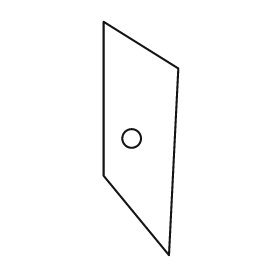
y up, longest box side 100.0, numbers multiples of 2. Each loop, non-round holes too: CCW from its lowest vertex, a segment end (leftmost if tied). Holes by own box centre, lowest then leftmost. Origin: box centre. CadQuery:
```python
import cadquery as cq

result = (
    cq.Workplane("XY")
    .moveTo(12.0, -50.0)
    .lineTo(16.0, 30.0)
    .lineTo(-16.0, 50.0)
    .lineTo(-16.0, -16.0)
    .close()
    .moveTo(-4.0, 0.0)
    .circle(4.0)
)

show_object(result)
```